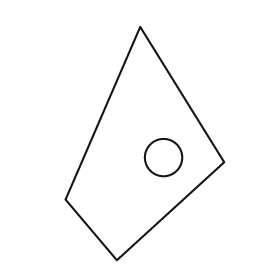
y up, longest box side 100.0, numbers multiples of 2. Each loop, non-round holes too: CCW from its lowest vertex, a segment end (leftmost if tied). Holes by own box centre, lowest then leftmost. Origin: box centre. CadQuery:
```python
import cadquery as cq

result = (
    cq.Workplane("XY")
    .moveTo(-12.0, -50.0)
    .lineTo(34.0, -8.0)
    .lineTo(-2.0, 50.0)
    .lineTo(-34.0, -24.0)
    .close()
    .moveTo(8.0, -6.0)
    .circle(8.0)
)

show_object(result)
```